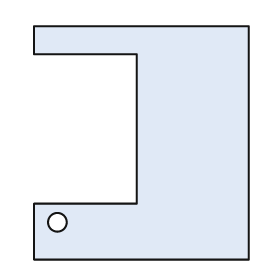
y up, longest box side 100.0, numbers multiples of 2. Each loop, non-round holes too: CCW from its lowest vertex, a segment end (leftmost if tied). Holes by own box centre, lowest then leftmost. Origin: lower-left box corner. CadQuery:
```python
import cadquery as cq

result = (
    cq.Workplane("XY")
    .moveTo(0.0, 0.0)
    .lineTo(92.0, 0.0)
    .lineTo(92.0, 100.0)
    .lineTo(0.0, 100.0)
    .lineTo(0.0, 88.0)
    .lineTo(44.0, 88.0)
    .lineTo(44.0, 24.0)
    .lineTo(0.0, 24.0)
    .close()
    .moveTo(10.0, 16.0)
    .circle(4.0)
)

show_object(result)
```